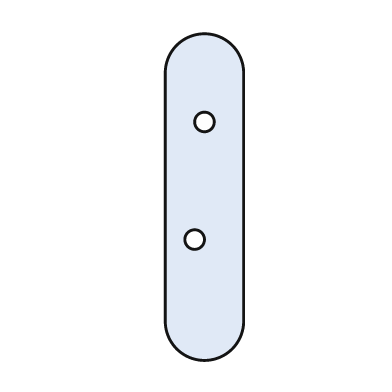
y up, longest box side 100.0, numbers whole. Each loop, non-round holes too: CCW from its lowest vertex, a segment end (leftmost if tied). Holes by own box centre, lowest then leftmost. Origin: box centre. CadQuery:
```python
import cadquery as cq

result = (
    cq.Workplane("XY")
    .moveTo(-12.0, -38.0)
    .threePointArc((0.0, -50.0), (12.0, -38.0))
    .lineTo(12.0, 38.0)
    .threePointArc((0.0, 50.0), (-12.0, 38.0))
    .close()
    .moveTo(-3.0, -13.0)
    .circle(3.0)
    .moveTo(0.0, 23.0)
    .circle(3.0)
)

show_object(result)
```